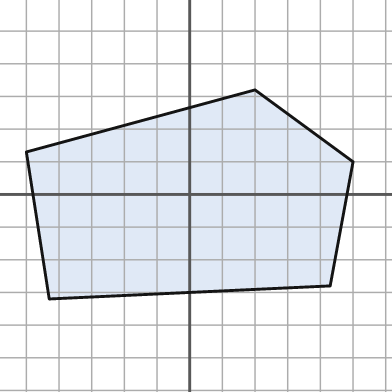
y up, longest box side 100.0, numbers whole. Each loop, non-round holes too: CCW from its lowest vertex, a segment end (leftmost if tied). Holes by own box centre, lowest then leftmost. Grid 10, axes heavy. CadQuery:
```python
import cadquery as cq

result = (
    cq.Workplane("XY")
    .moveTo(-43.0, -32.0)
    .lineTo(43.0, -28.0)
    .lineTo(50.0, 10.0)
    .lineTo(20.0, 32.0)
    .lineTo(-50.0, 13.0)
    .close()
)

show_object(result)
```